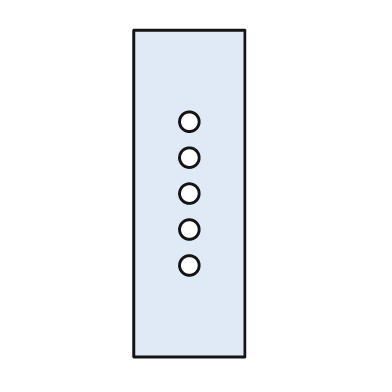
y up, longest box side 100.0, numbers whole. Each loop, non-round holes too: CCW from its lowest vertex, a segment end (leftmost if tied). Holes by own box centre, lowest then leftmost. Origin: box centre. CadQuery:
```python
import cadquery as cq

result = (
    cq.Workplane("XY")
    .moveTo(-17.0, -50.0)
    .lineTo(17.0, -50.0)
    .lineTo(17.0, 50.0)
    .lineTo(-17.0, 50.0)
    .close()
    .moveTo(0.0, -22.0)
    .circle(3.0)
    .moveTo(0.0, -11.0)
    .circle(3.0)
    .moveTo(0.0, 0.0)
    .circle(3.0)
    .moveTo(0.0, 11.0)
    .circle(3.0)
    .moveTo(0.0, 22.0)
    .circle(3.0)
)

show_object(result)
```